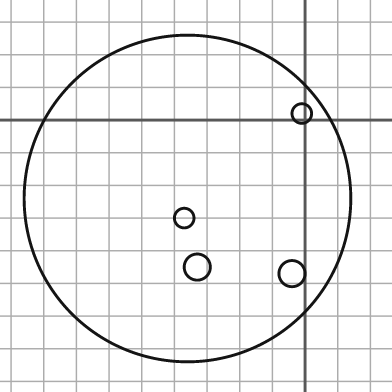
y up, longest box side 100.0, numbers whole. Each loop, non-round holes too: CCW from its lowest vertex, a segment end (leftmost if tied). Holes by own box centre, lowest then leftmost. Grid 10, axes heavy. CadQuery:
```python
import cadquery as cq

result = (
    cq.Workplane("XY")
    .moveTo(-36.0, -24.0)
    .circle(50.0)
    .moveTo(-4.0, -47.0)
    .circle(4.0)
    .moveTo(-33.0, -45.0)
    .circle(4.0)
    .moveTo(-37.0, -30.0)
    .circle(3.0)
    .moveTo(-1.0, 2.0)
    .circle(3.0)
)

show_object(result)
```